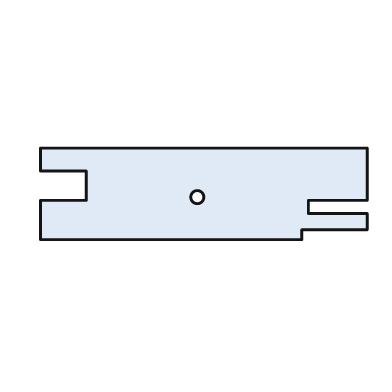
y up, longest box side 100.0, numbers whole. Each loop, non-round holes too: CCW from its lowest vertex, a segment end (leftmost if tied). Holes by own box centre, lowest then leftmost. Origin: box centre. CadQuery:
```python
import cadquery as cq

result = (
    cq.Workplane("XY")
    .moveTo(-50.0, -14.0)
    .lineTo(30.0, -14.0)
    .lineTo(30.0, -11.0)
    .lineTo(50.0, -11.0)
    .lineTo(50.0, -6.0)
    .lineTo(32.0, -6.0)
    .lineTo(32.0, -2.0)
    .lineTo(50.0, -2.0)
    .lineTo(50.0, 14.0)
    .lineTo(-50.0, 14.0)
    .lineTo(-50.0, 7.0)
    .lineTo(-36.0, 7.0)
    .lineTo(-36.0, -2.0)
    .lineTo(-50.0, -2.0)
    .close()
    .moveTo(-2.0, -1.0)
    .circle(2.0)
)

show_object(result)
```